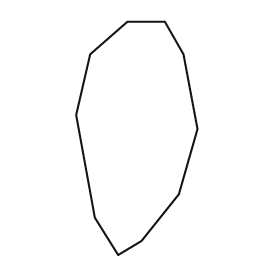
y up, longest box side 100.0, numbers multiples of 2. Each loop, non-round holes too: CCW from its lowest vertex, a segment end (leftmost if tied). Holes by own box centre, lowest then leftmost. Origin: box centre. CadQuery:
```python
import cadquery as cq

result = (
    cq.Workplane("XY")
    .moveTo(-8.0, -50.0)
    .lineTo(2.0, -44.0)
    .lineTo(18.0, -24.0)
    .lineTo(26.0, 4.0)
    .lineTo(20.0, 36.0)
    .lineTo(12.0, 50.0)
    .lineTo(-4.0, 50.0)
    .lineTo(-20.0, 36.0)
    .lineTo(-26.0, 10.0)
    .lineTo(-18.0, -34.0)
    .close()
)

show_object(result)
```